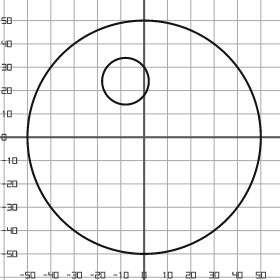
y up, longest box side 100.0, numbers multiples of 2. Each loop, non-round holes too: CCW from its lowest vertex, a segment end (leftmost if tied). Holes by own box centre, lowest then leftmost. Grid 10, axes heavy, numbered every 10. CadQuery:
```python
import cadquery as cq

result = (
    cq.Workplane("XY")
    .moveTo(0.0, 0.0)
    .circle(50.0)
    .moveTo(-8.0, 24.0)
    .circle(10.0)
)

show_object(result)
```